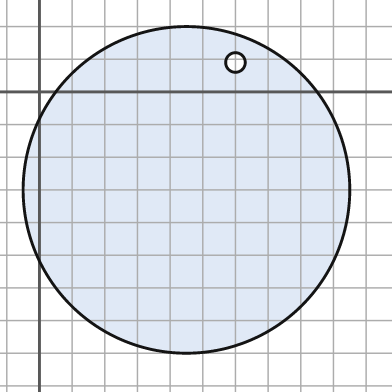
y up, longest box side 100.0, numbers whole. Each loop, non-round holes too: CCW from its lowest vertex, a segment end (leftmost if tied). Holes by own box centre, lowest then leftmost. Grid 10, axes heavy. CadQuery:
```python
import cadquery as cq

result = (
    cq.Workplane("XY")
    .moveTo(45.0, -30.0)
    .circle(50.0)
    .moveTo(60.0, 9.0)
    .circle(3.0)
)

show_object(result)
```